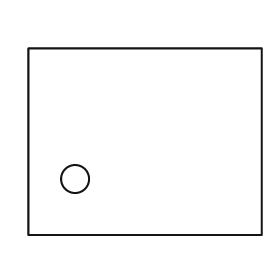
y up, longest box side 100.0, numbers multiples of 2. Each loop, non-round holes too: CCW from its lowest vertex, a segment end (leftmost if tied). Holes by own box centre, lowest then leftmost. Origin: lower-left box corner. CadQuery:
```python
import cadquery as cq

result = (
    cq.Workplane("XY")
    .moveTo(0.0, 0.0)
    .lineTo(100.0, 0.0)
    .lineTo(100.0, 80.0)
    .lineTo(0.0, 80.0)
    .close()
    .moveTo(20.0, 24.0)
    .circle(6.0)
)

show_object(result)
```